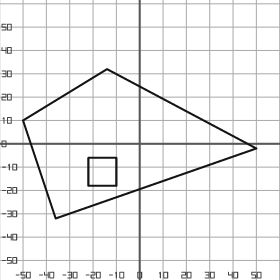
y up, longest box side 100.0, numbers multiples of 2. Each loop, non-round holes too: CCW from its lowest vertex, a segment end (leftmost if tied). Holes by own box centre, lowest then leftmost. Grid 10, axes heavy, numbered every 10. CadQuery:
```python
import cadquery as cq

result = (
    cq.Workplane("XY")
    .moveTo(-36.0, -32.0)
    .lineTo(50.0, -2.0)
    .lineTo(-14.0, 32.0)
    .lineTo(-50.0, 10.0)
    .close()
    .moveTo(-22.0, -18.0)
    .lineTo(-10.0, -18.0)
    .lineTo(-10.0, -6.0)
    .lineTo(-22.0, -6.0)
    .close()
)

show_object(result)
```